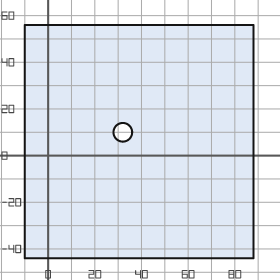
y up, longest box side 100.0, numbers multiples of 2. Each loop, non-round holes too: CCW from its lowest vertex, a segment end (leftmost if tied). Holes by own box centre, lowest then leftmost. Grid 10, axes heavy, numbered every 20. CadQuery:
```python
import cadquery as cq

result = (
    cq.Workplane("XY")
    .moveTo(-10.0, -44.0)
    .lineTo(88.0, -44.0)
    .lineTo(88.0, 56.0)
    .lineTo(-10.0, 56.0)
    .close()
    .moveTo(32.0, 10.0)
    .circle(4.0)
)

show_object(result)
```